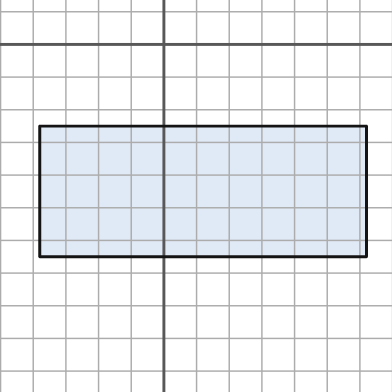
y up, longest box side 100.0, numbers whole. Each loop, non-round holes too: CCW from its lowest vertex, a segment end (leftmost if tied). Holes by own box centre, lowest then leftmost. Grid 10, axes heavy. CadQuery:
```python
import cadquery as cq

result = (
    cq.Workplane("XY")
    .moveTo(-38.0, -65.0)
    .lineTo(62.0, -65.0)
    .lineTo(62.0, -25.0)
    .lineTo(-38.0, -25.0)
    .close()
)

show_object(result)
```